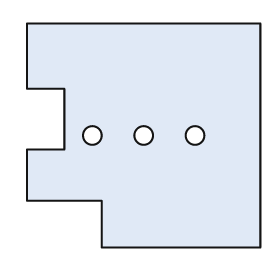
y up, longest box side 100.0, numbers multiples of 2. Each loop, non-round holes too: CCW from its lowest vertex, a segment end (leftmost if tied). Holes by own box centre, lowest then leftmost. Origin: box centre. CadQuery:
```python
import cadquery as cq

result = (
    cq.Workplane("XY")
    .moveTo(-18.0, -48.0)
    .lineTo(50.0, -48.0)
    .lineTo(50.0, 48.0)
    .lineTo(-50.0, 48.0)
    .lineTo(-50.0, 20.0)
    .lineTo(-34.0, 20.0)
    .lineTo(-34.0, -6.0)
    .lineTo(-50.0, -6.0)
    .lineTo(-50.0, -28.0)
    .lineTo(-18.0, -28.0)
    .close()
    .moveTo(-22.0, 0.0)
    .circle(4.0)
    .moveTo(0.0, 0.0)
    .circle(4.0)
    .moveTo(22.0, 0.0)
    .circle(4.0)
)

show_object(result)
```